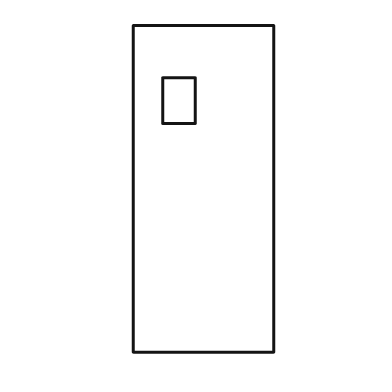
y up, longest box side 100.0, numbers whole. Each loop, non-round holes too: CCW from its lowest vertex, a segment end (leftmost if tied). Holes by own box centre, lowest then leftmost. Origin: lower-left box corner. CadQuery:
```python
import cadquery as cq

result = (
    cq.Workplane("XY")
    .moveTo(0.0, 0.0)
    .lineTo(43.0, 0.0)
    .lineTo(43.0, 100.0)
    .lineTo(0.0, 100.0)
    .close()
    .moveTo(9.0, 70.0)
    .lineTo(19.0, 70.0)
    .lineTo(19.0, 84.0)
    .lineTo(9.0, 84.0)
    .close()
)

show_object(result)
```